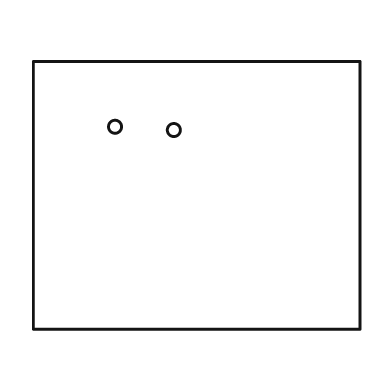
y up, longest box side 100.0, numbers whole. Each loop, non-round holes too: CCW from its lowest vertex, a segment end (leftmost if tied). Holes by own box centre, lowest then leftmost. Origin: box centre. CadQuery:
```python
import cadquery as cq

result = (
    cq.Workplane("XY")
    .moveTo(-50.0, -41.0)
    .lineTo(50.0, -41.0)
    .lineTo(50.0, 41.0)
    .lineTo(-50.0, 41.0)
    .close()
    .moveTo(-7.0, 20.0)
    .circle(2.0)
    .moveTo(-25.0, 21.0)
    .circle(2.0)
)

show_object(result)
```